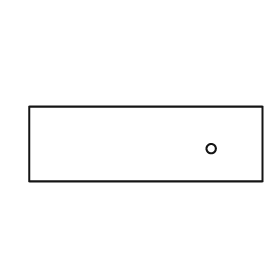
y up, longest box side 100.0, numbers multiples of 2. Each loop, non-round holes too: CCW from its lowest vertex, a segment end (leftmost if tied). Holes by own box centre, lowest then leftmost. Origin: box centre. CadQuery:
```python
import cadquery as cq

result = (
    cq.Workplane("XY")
    .moveTo(-50.0, -16.0)
    .lineTo(50.0, -16.0)
    .lineTo(50.0, 16.0)
    .lineTo(-50.0, 16.0)
    .close()
    .moveTo(28.0, -2.0)
    .circle(2.0)
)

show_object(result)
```